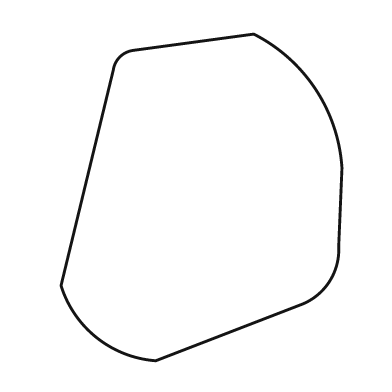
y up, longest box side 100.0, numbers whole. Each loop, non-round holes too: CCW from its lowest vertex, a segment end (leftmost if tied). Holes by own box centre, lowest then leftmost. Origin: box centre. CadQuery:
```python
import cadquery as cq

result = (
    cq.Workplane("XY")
    .moveTo(-14.0, -50.0)
    .lineTo(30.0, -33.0)
    .threePointArc((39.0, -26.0), (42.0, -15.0))
    .lineTo(43.0, 9.0)
    .threePointArc((35.0, 33.0), (16.0, 50.0))
    .lineTo(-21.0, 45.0)
    .threePointArc((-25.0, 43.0), (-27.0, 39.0))
    .lineTo(-43.0, -27.0)
    .threePointArc((-32.0, -43.0), (-14.0, -50.0))
    .close()
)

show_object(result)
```